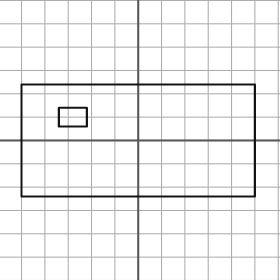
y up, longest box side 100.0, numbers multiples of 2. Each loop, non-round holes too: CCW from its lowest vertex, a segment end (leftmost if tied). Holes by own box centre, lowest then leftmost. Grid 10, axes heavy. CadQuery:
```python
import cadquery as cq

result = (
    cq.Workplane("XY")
    .moveTo(-50.0, -24.0)
    .lineTo(50.0, -24.0)
    .lineTo(50.0, 24.0)
    .lineTo(-50.0, 24.0)
    .close()
    .moveTo(-34.0, 6.0)
    .lineTo(-22.0, 6.0)
    .lineTo(-22.0, 14.0)
    .lineTo(-34.0, 14.0)
    .close()
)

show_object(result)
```